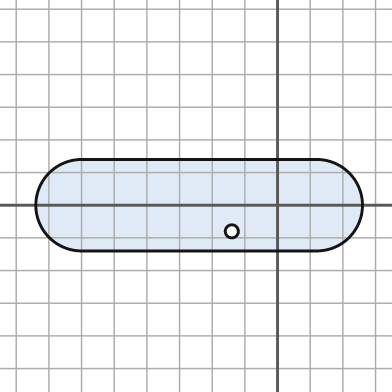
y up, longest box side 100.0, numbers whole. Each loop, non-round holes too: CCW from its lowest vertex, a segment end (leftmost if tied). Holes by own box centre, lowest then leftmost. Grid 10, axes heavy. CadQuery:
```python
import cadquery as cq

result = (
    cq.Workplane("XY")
    .moveTo(-60.0, -14.0)
    .lineTo(12.0, -14.0)
    .threePointArc((26.0, 0.0), (12.0, 14.0))
    .lineTo(-60.0, 14.0)
    .threePointArc((-74.0, 0.0), (-60.0, -14.0))
    .close()
    .moveTo(-14.0, -8.0)
    .circle(2.0)
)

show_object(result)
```